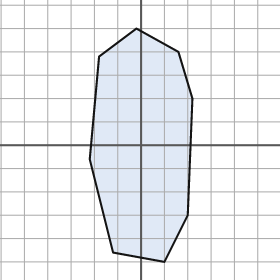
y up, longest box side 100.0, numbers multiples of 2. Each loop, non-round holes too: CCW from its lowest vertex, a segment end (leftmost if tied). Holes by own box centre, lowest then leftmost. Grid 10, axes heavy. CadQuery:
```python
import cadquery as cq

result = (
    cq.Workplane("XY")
    .moveTo(10.0, -50.0)
    .lineTo(20.0, -30.0)
    .lineTo(22.0, 20.0)
    .lineTo(16.0, 40.0)
    .lineTo(-2.0, 50.0)
    .lineTo(-18.0, 38.0)
    .lineTo(-22.0, -6.0)
    .lineTo(-12.0, -46.0)
    .close()
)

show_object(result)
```